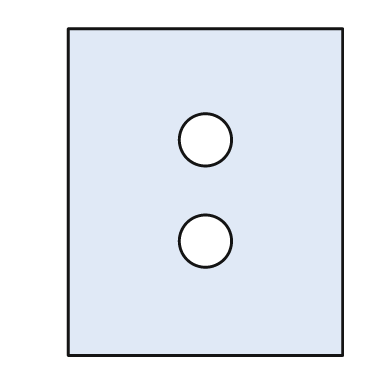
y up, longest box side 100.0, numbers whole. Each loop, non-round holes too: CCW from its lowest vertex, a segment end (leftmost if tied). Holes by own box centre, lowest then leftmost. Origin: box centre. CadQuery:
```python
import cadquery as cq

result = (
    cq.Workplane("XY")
    .moveTo(-42.0, -50.0)
    .lineTo(42.0, -50.0)
    .lineTo(42.0, 50.0)
    .lineTo(-42.0, 50.0)
    .close()
    .moveTo(0.0, -15.0)
    .circle(8.0)
    .moveTo(0.0, 16.0)
    .circle(8.0)
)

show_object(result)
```